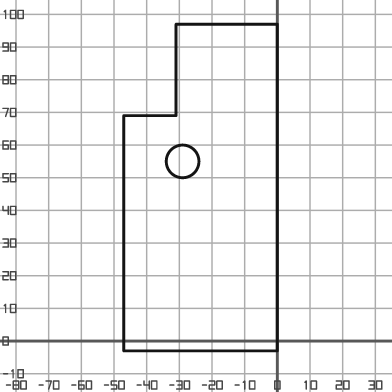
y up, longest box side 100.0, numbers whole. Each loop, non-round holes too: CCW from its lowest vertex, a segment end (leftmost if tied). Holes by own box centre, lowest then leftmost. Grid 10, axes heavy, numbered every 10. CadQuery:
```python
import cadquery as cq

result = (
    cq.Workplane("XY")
    .moveTo(-47.0, -3.0)
    .lineTo(0.0, -3.0)
    .lineTo(0.0, 97.0)
    .lineTo(-31.0, 97.0)
    .lineTo(-31.0, 69.0)
    .lineTo(-47.0, 69.0)
    .close()
    .moveTo(-29.0, 55.0)
    .circle(5.0)
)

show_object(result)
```